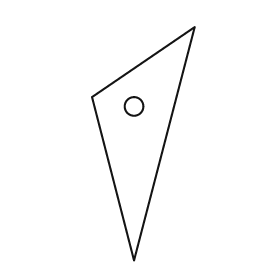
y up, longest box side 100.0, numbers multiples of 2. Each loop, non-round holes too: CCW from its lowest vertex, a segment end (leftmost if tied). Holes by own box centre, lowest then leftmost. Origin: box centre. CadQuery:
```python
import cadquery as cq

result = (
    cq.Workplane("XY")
    .moveTo(-4.0, -50.0)
    .lineTo(22.0, 50.0)
    .lineTo(-22.0, 20.0)
    .close()
    .moveTo(-4.0, 16.0)
    .circle(4.0)
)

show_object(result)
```